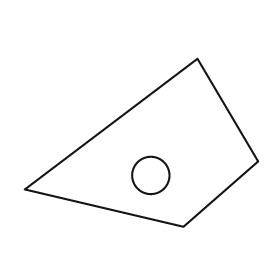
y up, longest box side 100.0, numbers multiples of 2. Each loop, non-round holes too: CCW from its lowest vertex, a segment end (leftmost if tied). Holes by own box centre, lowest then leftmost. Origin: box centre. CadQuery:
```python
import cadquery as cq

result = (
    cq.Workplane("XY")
    .moveTo(18.0, -36.0)
    .lineTo(50.0, -8.0)
    .lineTo(24.0, 36.0)
    .lineTo(-50.0, -20.0)
    .close()
    .moveTo(4.0, -14.0)
    .circle(8.0)
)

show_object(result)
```